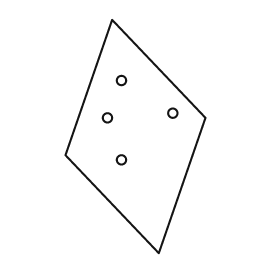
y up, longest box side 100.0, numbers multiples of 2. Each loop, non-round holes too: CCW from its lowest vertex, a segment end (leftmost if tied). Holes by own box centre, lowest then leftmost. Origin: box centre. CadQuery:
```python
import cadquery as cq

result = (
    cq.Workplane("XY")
    .moveTo(10.0, -50.0)
    .lineTo(30.0, 8.0)
    .lineTo(-10.0, 50.0)
    .lineTo(-30.0, -8.0)
    .close()
    .moveTo(-6.0, -10.0)
    .circle(2.0)
    .moveTo(-12.0, 8.0)
    .circle(2.0)
    .moveTo(16.0, 10.0)
    .circle(2.0)
    .moveTo(-6.0, 24.0)
    .circle(2.0)
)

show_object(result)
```